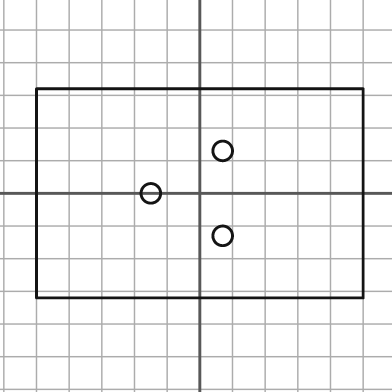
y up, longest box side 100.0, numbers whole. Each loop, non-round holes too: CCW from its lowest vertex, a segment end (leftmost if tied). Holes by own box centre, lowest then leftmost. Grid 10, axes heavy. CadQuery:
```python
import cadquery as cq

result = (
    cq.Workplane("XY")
    .moveTo(-50.0, -32.0)
    .lineTo(50.0, -32.0)
    .lineTo(50.0, 32.0)
    .lineTo(-50.0, 32.0)
    .close()
    .moveTo(7.0, -13.0)
    .circle(3.0)
    .moveTo(-15.0, 0.0)
    .circle(3.0)
    .moveTo(7.0, 13.0)
    .circle(3.0)
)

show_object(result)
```